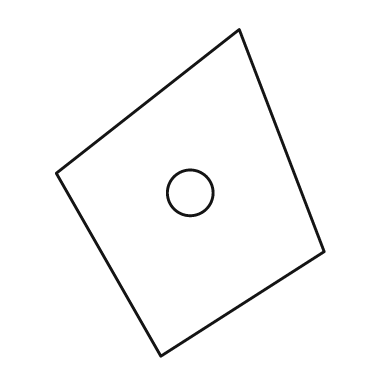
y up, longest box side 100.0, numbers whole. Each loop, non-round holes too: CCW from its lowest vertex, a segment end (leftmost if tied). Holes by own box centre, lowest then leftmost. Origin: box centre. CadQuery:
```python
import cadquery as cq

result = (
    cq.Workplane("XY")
    .moveTo(-9.0, -50.0)
    .lineTo(41.0, -18.0)
    .lineTo(15.0, 50.0)
    .lineTo(-41.0, 6.0)
    .close()
    .moveTo(0.0, 0.0)
    .circle(7.0)
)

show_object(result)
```